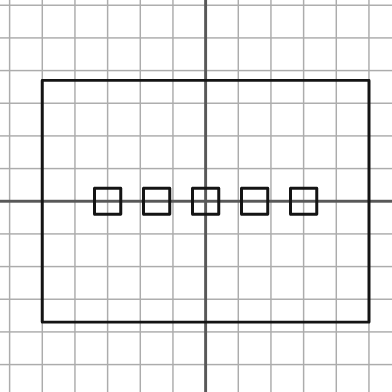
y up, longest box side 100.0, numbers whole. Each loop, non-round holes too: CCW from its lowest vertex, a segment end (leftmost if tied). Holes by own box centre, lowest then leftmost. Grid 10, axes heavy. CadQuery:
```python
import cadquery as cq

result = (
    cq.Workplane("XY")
    .moveTo(-50.0, -37.0)
    .lineTo(50.0, -37.0)
    .lineTo(50.0, 37.0)
    .lineTo(-50.0, 37.0)
    .close()
    .moveTo(-34.0, -4.0)
    .lineTo(-26.0, -4.0)
    .lineTo(-26.0, 4.0)
    .lineTo(-34.0, 4.0)
    .close()
    .moveTo(-19.0, -4.0)
    .lineTo(-11.0, -4.0)
    .lineTo(-11.0, 4.0)
    .lineTo(-19.0, 4.0)
    .close()
    .moveTo(-4.0, -4.0)
    .lineTo(4.0, -4.0)
    .lineTo(4.0, 4.0)
    .lineTo(-4.0, 4.0)
    .close()
    .moveTo(11.0, -4.0)
    .lineTo(19.0, -4.0)
    .lineTo(19.0, 4.0)
    .lineTo(11.0, 4.0)
    .close()
    .moveTo(26.0, -4.0)
    .lineTo(34.0, -4.0)
    .lineTo(34.0, 4.0)
    .lineTo(26.0, 4.0)
    .close()
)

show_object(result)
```